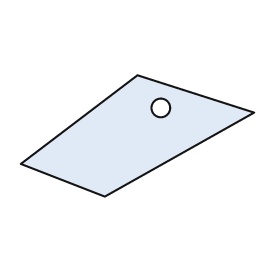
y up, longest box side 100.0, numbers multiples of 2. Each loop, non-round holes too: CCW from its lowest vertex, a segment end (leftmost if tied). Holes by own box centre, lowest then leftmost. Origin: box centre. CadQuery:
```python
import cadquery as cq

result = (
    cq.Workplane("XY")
    .moveTo(-14.0, -26.0)
    .lineTo(50.0, 10.0)
    .lineTo(0.0, 26.0)
    .lineTo(-50.0, -12.0)
    .close()
    .moveTo(10.0, 12.0)
    .circle(4.0)
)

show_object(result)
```